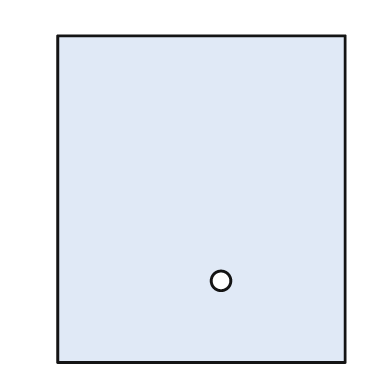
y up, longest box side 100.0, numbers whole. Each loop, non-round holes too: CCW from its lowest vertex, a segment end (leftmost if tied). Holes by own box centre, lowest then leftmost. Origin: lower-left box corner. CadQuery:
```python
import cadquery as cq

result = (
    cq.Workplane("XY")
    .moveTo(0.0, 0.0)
    .lineTo(88.0, 0.0)
    .lineTo(88.0, 100.0)
    .lineTo(0.0, 100.0)
    .close()
    .moveTo(50.0, 25.0)
    .circle(3.0)
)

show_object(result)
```